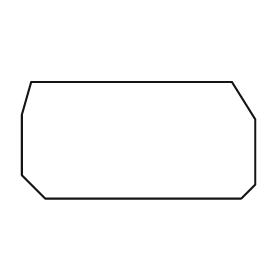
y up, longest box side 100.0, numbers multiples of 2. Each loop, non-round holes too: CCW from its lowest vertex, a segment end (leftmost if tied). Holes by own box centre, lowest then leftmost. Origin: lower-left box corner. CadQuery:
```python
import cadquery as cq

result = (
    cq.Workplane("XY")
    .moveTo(10.0, 0.0)
    .lineTo(94.0, 0.0)
    .lineTo(100.0, 6.0)
    .lineTo(100.0, 34.0)
    .lineTo(90.0, 50.0)
    .lineTo(4.0, 50.0)
    .lineTo(0.0, 36.0)
    .lineTo(0.0, 10.0)
    .close()
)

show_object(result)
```